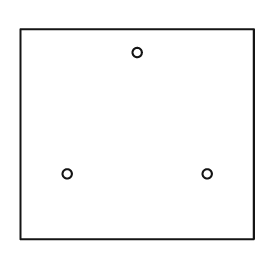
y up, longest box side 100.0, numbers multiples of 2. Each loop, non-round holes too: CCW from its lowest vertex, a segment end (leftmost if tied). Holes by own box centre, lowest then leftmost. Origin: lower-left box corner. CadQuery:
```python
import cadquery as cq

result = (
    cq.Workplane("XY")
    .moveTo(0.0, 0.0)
    .lineTo(100.0, 0.0)
    .lineTo(100.0, 90.0)
    .lineTo(0.0, 90.0)
    .close()
    .moveTo(20.0, 28.0)
    .circle(2.0)
    .moveTo(80.0, 28.0)
    .circle(2.0)
    .moveTo(50.0, 80.0)
    .circle(2.0)
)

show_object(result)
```